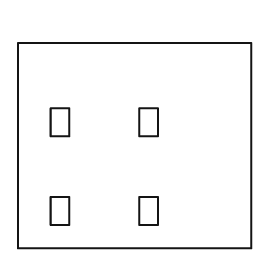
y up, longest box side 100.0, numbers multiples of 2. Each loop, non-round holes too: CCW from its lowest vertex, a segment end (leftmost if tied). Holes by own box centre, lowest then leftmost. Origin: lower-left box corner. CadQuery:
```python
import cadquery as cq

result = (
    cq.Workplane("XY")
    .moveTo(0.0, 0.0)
    .lineTo(100.0, 0.0)
    .lineTo(100.0, 88.0)
    .lineTo(0.0, 88.0)
    .close()
    .moveTo(14.0, 10.0)
    .lineTo(22.0, 10.0)
    .lineTo(22.0, 22.0)
    .lineTo(14.0, 22.0)
    .close()
    .moveTo(52.0, 10.0)
    .lineTo(60.0, 10.0)
    .lineTo(60.0, 22.0)
    .lineTo(52.0, 22.0)
    .close()
    .moveTo(14.0, 48.0)
    .lineTo(22.0, 48.0)
    .lineTo(22.0, 60.0)
    .lineTo(14.0, 60.0)
    .close()
    .moveTo(52.0, 48.0)
    .lineTo(60.0, 48.0)
    .lineTo(60.0, 60.0)
    .lineTo(52.0, 60.0)
    .close()
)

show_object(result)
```